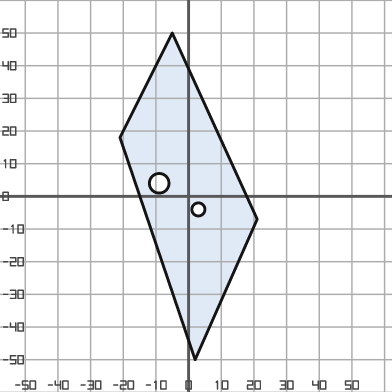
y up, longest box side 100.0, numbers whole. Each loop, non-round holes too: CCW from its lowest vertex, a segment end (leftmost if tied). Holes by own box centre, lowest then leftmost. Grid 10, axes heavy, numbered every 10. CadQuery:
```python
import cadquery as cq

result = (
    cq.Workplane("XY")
    .moveTo(2.0, -50.0)
    .lineTo(21.0, -7.0)
    .lineTo(-5.0, 50.0)
    .lineTo(-21.0, 18.0)
    .close()
    .moveTo(3.0, -4.0)
    .circle(2.0)
    .moveTo(-9.0, 4.0)
    .circle(3.0)
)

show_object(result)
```